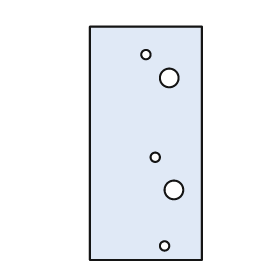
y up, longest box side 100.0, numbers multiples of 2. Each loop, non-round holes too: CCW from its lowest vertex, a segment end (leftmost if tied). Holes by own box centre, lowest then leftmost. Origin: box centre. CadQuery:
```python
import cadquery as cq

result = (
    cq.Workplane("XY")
    .moveTo(-24.0, -50.0)
    .lineTo(24.0, -50.0)
    .lineTo(24.0, 50.0)
    .lineTo(-24.0, 50.0)
    .close()
    .moveTo(8.0, -44.0)
    .circle(2.0)
    .moveTo(12.0, -20.0)
    .circle(4.0)
    .moveTo(4.0, -6.0)
    .circle(2.0)
    .moveTo(10.0, 28.0)
    .circle(4.0)
    .moveTo(0.0, 38.0)
    .circle(2.0)
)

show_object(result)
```